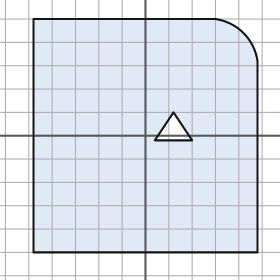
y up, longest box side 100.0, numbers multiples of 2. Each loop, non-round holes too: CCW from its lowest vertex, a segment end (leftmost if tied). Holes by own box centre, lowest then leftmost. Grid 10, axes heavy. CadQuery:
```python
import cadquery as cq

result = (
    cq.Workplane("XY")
    .moveTo(-48.0, -50.0)
    .lineTo(48.0, -50.0)
    .lineTo(48.0, 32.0)
    .threePointArc((42.0, 44.0), (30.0, 50.0))
    .lineTo(-48.0, 50.0)
    .close()
    .moveTo(4.0, -2.0)
    .lineTo(20.0, -2.0)
    .lineTo(12.0, 10.0)
    .close()
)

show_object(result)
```